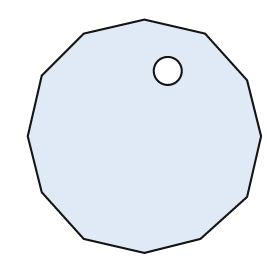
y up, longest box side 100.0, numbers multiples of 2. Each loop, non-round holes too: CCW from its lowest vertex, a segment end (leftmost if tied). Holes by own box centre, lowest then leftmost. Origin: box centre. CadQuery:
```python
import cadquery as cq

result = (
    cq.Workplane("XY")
    .moveTo(0.0, -50.0)
    .lineTo(24.0, -44.0)
    .lineTo(44.0, -26.0)
    .lineTo(50.0, 0.0)
    .lineTo(44.0, 24.0)
    .lineTo(26.0, 44.0)
    .lineTo(0.0, 50.0)
    .lineTo(-26.0, 44.0)
    .lineTo(-44.0, 26.0)
    .lineTo(-50.0, 0.0)
    .lineTo(-44.0, -24.0)
    .lineTo(-26.0, -44.0)
    .close()
    .moveTo(10.0, 28.0)
    .circle(6.0)
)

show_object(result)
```